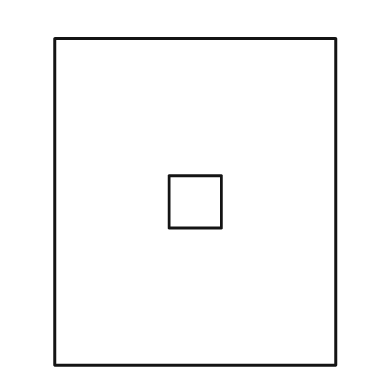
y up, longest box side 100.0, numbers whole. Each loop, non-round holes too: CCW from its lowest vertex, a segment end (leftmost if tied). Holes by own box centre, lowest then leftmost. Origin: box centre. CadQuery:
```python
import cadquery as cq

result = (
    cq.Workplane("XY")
    .moveTo(-43.0, -50.0)
    .lineTo(43.0, -50.0)
    .lineTo(43.0, 50.0)
    .lineTo(-43.0, 50.0)
    .close()
    .moveTo(-8.0, -8.0)
    .lineTo(8.0, -8.0)
    .lineTo(8.0, 8.0)
    .lineTo(-8.0, 8.0)
    .close()
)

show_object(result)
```